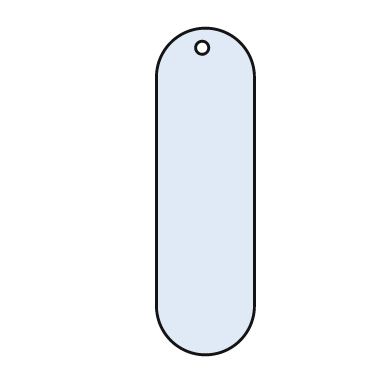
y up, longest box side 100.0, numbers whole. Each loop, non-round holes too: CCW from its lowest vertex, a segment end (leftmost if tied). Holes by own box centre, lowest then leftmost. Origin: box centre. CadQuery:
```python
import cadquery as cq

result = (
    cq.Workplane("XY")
    .moveTo(-15.0, -35.0)
    .threePointArc((0.0, -50.0), (15.0, -35.0))
    .lineTo(15.0, 35.0)
    .threePointArc((0.0, 50.0), (-15.0, 35.0))
    .close()
    .moveTo(-1.0, 44.0)
    .circle(2.0)
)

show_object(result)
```